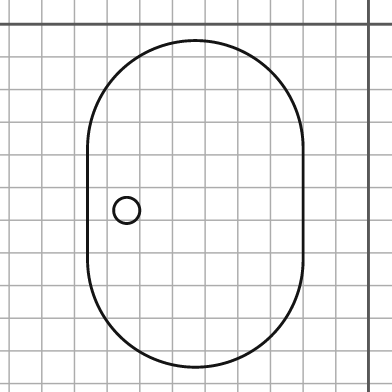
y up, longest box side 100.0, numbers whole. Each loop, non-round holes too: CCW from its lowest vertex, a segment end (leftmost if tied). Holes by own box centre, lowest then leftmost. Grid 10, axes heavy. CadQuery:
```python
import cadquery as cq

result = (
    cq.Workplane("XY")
    .moveTo(-86.0, -72.0)
    .threePointArc((-53.0, -105.0), (-20.0, -72.0))
    .lineTo(-20.0, -38.0)
    .threePointArc((-53.0, -5.0), (-86.0, -38.0))
    .close()
    .moveTo(-74.0, -57.0)
    .circle(4.0)
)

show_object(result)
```